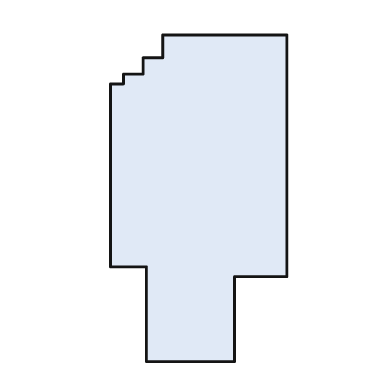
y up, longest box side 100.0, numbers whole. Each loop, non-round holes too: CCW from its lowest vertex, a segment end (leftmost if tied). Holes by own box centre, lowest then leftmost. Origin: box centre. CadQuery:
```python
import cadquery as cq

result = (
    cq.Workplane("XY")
    .moveTo(-16.0, -50.0)
    .lineTo(11.0, -50.0)
    .lineTo(11.0, -24.0)
    .lineTo(27.0, -24.0)
    .lineTo(27.0, 50.0)
    .lineTo(-11.0, 50.0)
    .lineTo(-11.0, 43.0)
    .lineTo(-17.0, 43.0)
    .lineTo(-17.0, 38.0)
    .lineTo(-23.0, 38.0)
    .lineTo(-23.0, 35.0)
    .lineTo(-27.0, 35.0)
    .lineTo(-27.0, -21.0)
    .lineTo(-16.0, -21.0)
    .close()
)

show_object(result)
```